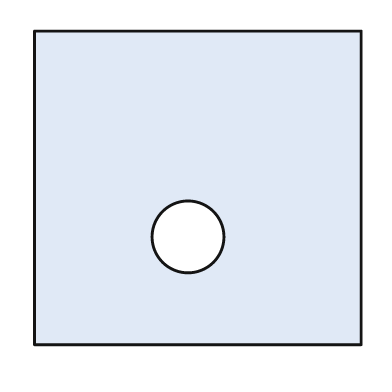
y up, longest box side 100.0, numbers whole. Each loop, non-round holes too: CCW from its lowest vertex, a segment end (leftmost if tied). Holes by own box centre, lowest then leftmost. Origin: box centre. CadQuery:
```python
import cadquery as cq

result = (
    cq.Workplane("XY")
    .moveTo(-50.0, -48.0)
    .lineTo(50.0, -48.0)
    .lineTo(50.0, 48.0)
    .lineTo(-50.0, 48.0)
    .close()
    .moveTo(-3.0, -15.0)
    .circle(11.0)
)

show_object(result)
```